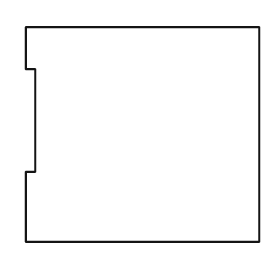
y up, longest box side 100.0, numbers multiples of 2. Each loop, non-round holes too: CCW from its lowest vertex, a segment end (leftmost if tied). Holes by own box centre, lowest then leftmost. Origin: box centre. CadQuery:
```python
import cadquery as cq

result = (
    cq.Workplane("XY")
    .moveTo(-50.0, -46.0)
    .lineTo(50.0, -46.0)
    .lineTo(50.0, 46.0)
    .lineTo(-50.0, 46.0)
    .lineTo(-50.0, 28.0)
    .lineTo(-46.0, 28.0)
    .lineTo(-46.0, -16.0)
    .lineTo(-50.0, -16.0)
    .close()
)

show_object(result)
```